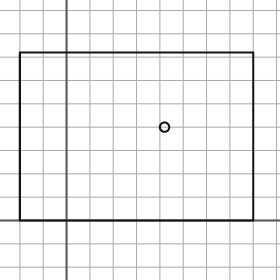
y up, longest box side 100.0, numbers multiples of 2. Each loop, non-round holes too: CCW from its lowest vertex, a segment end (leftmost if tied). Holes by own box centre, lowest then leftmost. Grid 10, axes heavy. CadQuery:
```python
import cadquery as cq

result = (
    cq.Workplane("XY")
    .moveTo(-20.0, 0.0)
    .lineTo(80.0, 0.0)
    .lineTo(80.0, 72.0)
    .lineTo(-20.0, 72.0)
    .close()
    .moveTo(42.0, 40.0)
    .circle(2.0)
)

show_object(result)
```